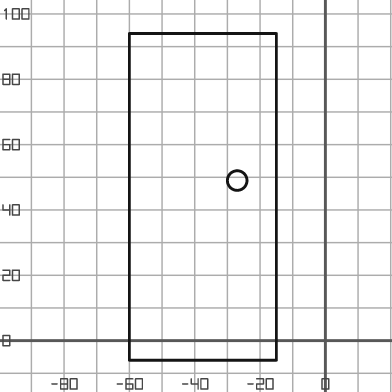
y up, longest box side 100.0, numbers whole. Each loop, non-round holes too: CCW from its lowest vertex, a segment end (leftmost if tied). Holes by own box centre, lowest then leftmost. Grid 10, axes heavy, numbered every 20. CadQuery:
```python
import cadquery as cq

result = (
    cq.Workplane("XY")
    .moveTo(-60.0, -6.0)
    .lineTo(-15.0, -6.0)
    .lineTo(-15.0, 94.0)
    .lineTo(-60.0, 94.0)
    .close()
    .moveTo(-27.0, 49.0)
    .circle(3.0)
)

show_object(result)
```